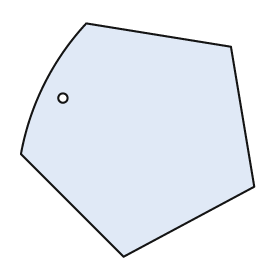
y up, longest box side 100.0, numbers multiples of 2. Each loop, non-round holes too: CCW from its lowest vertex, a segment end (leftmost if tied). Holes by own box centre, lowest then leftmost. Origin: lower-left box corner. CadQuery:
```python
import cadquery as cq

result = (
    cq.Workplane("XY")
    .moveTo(44.0, 0.0)
    .lineTo(100.0, 30.0)
    .lineTo(90.0, 90.0)
    .lineTo(28.0, 100.0)
    .threePointArc((10.0, 74.0), (0.0, 44.0))
    .close()
    .moveTo(18.0, 68.0)
    .circle(2.0)
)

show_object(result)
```